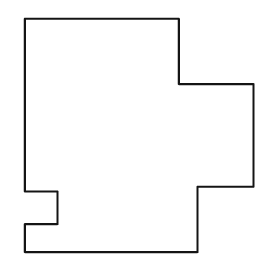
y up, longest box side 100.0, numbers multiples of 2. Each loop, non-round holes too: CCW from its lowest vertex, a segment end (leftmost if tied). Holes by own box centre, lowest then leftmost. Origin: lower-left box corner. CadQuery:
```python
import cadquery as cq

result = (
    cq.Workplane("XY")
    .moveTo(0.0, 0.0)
    .lineTo(74.0, 0.0)
    .lineTo(74.0, 28.0)
    .lineTo(98.0, 28.0)
    .lineTo(98.0, 72.0)
    .lineTo(66.0, 72.0)
    .lineTo(66.0, 100.0)
    .lineTo(0.0, 100.0)
    .lineTo(0.0, 26.0)
    .lineTo(14.0, 26.0)
    .lineTo(14.0, 12.0)
    .lineTo(0.0, 12.0)
    .close()
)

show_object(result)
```